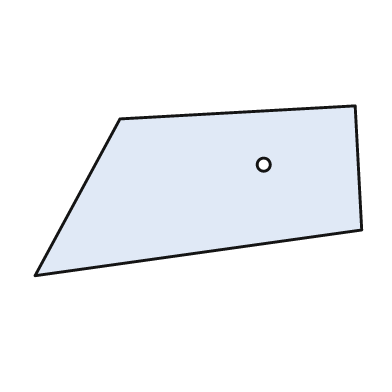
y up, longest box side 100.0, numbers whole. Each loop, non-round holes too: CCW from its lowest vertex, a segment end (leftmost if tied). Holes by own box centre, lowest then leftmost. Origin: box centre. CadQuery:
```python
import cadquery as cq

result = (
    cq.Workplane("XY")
    .moveTo(-50.0, -26.0)
    .lineTo(50.0, -12.0)
    .lineTo(48.0, 26.0)
    .lineTo(-24.0, 22.0)
    .close()
    .moveTo(20.0, 8.0)
    .circle(2.0)
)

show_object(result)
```